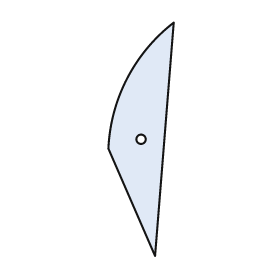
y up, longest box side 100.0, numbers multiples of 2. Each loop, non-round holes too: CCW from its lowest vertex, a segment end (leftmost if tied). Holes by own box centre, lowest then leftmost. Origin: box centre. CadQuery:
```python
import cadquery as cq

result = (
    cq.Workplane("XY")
    .moveTo(6.0, -50.0)
    .lineTo(14.0, 50.0)
    .threePointArc((-6.0, 26.0), (-14.0, -4.0))
    .close()
    .moveTo(0.0, 0.0)
    .circle(2.0)
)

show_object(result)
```